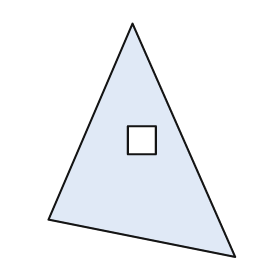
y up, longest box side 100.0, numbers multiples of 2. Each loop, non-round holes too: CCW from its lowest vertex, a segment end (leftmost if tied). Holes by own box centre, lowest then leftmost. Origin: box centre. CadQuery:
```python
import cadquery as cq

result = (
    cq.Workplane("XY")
    .moveTo(40.0, -50.0)
    .lineTo(-4.0, 50.0)
    .lineTo(-40.0, -34.0)
    .close()
    .moveTo(-6.0, -6.0)
    .lineTo(6.0, -6.0)
    .lineTo(6.0, 6.0)
    .lineTo(-6.0, 6.0)
    .close()
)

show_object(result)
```